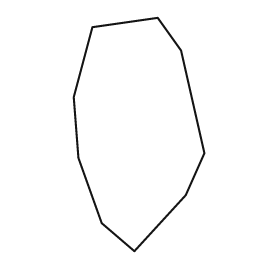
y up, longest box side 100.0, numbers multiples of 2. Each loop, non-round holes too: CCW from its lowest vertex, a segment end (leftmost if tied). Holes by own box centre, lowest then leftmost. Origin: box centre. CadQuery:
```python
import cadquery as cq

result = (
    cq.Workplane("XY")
    .moveTo(-2.0, -50.0)
    .lineTo(20.0, -26.0)
    .lineTo(28.0, -8.0)
    .lineTo(18.0, 36.0)
    .lineTo(8.0, 50.0)
    .lineTo(-20.0, 46.0)
    .lineTo(-28.0, 16.0)
    .lineTo(-26.0, -10.0)
    .lineTo(-16.0, -38.0)
    .close()
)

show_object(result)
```